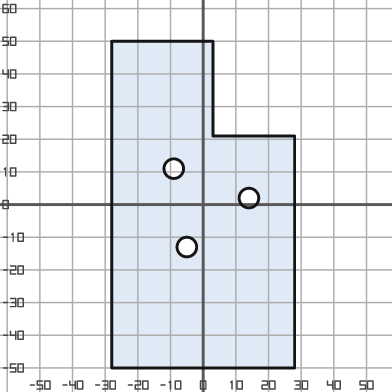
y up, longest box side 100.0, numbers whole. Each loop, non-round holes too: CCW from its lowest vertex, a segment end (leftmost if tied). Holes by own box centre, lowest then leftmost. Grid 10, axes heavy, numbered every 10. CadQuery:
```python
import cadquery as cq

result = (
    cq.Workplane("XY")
    .moveTo(-28.0, -50.0)
    .lineTo(28.0, -50.0)
    .lineTo(28.0, 21.0)
    .lineTo(3.0, 21.0)
    .lineTo(3.0, 50.0)
    .lineTo(-28.0, 50.0)
    .close()
    .moveTo(-5.0, -13.0)
    .circle(3.0)
    .moveTo(14.0, 2.0)
    .circle(3.0)
    .moveTo(-9.0, 11.0)
    .circle(3.0)
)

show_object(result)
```